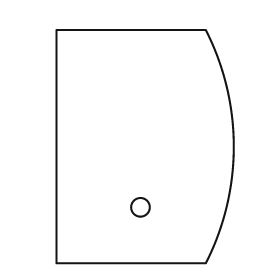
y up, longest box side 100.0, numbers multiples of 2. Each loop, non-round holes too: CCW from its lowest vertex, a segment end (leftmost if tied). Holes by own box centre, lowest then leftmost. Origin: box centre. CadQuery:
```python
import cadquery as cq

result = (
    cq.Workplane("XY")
    .moveTo(-38.0, -50.0)
    .lineTo(26.0, -50.0)
    .threePointArc((38.0, 0.0), (26.0, 50.0))
    .lineTo(-38.0, 50.0)
    .close()
    .moveTo(-2.0, -26.0)
    .circle(4.0)
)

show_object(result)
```